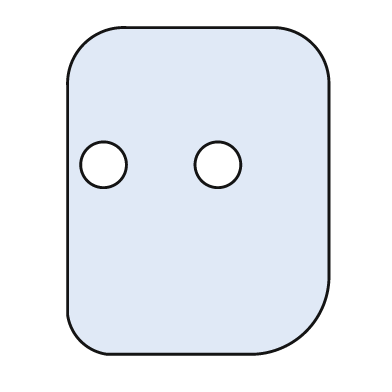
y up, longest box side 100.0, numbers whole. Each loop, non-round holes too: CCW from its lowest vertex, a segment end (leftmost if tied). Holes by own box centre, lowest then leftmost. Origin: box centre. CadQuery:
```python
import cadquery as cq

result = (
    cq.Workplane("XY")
    .moveTo(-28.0, -50.0)
    .lineTo(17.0, -50.0)
    .threePointArc((33.0, -43.0), (40.0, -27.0))
    .lineTo(40.0, 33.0)
    .threePointArc((35.0, 45.0), (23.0, 50.0))
    .lineTo(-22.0, 50.0)
    .threePointArc((-35.0, 45.0), (-40.0, 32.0))
    .lineTo(-40.0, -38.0)
    .threePointArc((-36.0, -46.0), (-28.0, -50.0))
    .close()
    .moveTo(-29.0, 8.0)
    .circle(7.0)
    .moveTo(6.0, 8.0)
    .circle(7.0)
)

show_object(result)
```